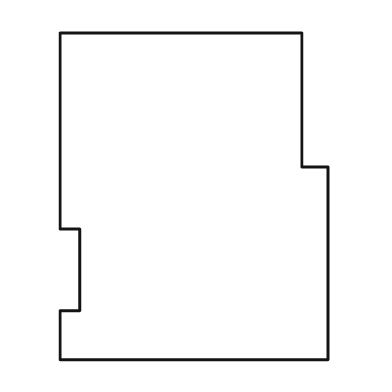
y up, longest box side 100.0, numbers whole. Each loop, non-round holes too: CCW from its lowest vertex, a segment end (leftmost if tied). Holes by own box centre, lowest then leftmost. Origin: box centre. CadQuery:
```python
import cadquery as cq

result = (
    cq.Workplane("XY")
    .moveTo(-41.0, -50.0)
    .lineTo(41.0, -50.0)
    .lineTo(41.0, 9.0)
    .lineTo(33.0, 9.0)
    .lineTo(33.0, 50.0)
    .lineTo(-41.0, 50.0)
    .lineTo(-41.0, -10.0)
    .lineTo(-35.0, -10.0)
    .lineTo(-35.0, -35.0)
    .lineTo(-41.0, -35.0)
    .close()
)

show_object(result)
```